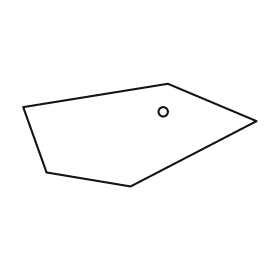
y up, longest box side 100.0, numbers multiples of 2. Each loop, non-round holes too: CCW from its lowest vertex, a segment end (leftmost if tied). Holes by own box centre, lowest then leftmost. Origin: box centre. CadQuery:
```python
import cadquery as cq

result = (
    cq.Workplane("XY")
    .moveTo(-4.0, -22.0)
    .lineTo(50.0, 6.0)
    .lineTo(12.0, 22.0)
    .lineTo(-50.0, 12.0)
    .lineTo(-40.0, -16.0)
    .close()
    .moveTo(10.0, 10.0)
    .circle(2.0)
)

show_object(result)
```